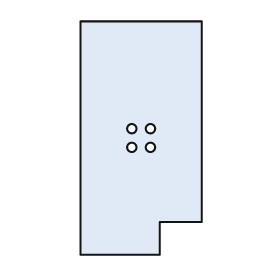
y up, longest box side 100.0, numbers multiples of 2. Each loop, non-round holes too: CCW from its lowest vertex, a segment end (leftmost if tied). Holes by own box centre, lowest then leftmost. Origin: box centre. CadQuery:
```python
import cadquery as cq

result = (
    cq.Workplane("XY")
    .moveTo(-26.0, -50.0)
    .lineTo(8.0, -50.0)
    .lineTo(8.0, -36.0)
    .lineTo(26.0, -36.0)
    .lineTo(26.0, 50.0)
    .lineTo(-26.0, 50.0)
    .close()
    .moveTo(-4.0, -4.0)
    .circle(2.0)
    .moveTo(4.0, -4.0)
    .circle(2.0)
    .moveTo(-4.0, 4.0)
    .circle(2.0)
    .moveTo(4.0, 4.0)
    .circle(2.0)
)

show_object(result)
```